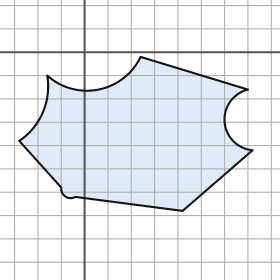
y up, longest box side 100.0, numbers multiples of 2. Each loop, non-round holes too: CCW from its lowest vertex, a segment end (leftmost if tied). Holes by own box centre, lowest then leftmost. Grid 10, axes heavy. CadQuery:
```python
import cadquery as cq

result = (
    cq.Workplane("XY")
    .moveTo(42.0, -68.0)
    .lineTo(72.0, -42.0)
    .threePointArc((60.0, -30.0), (70.0, -16.0))
    .lineTo(24.0, -2.0)
    .threePointArc((6.0, -16.0), (-16.0, -10.0))
    .threePointArc((-18.0, -26.0), (-28.0, -38.0))
    .lineTo(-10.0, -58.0)
    .threePointArc((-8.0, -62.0), (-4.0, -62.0))
    .close()
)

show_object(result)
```